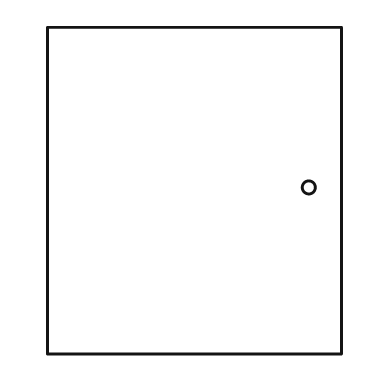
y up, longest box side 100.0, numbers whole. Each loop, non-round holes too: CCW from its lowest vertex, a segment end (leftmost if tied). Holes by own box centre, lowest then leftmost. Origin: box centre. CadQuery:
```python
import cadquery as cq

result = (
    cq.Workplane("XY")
    .moveTo(-45.0, -50.0)
    .lineTo(45.0, -50.0)
    .lineTo(45.0, 50.0)
    .lineTo(-45.0, 50.0)
    .close()
    .moveTo(35.0, 1.0)
    .circle(2.0)
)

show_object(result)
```